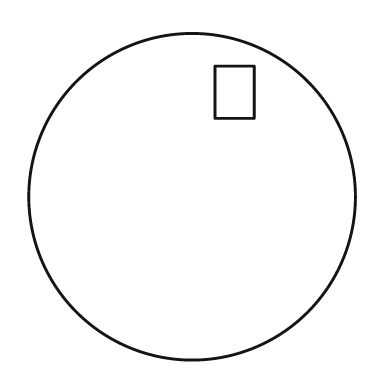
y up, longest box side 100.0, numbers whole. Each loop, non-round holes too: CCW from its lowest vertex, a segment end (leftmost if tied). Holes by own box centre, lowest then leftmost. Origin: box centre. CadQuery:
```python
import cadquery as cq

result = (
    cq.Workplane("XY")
    .moveTo(0.0, 0.0)
    .circle(50.0)
    .moveTo(7.0, 24.0)
    .lineTo(19.0, 24.0)
    .lineTo(19.0, 40.0)
    .lineTo(7.0, 40.0)
    .close()
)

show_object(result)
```